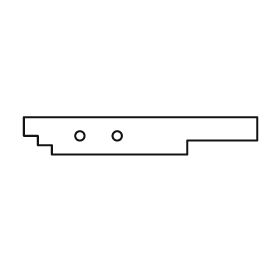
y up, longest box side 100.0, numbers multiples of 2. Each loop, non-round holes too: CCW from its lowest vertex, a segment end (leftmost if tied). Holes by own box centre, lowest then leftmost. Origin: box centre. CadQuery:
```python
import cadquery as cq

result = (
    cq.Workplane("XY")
    .moveTo(-38.0, -8.0)
    .lineTo(20.0, -8.0)
    .lineTo(20.0, -2.0)
    .lineTo(50.0, -2.0)
    .lineTo(50.0, 8.0)
    .lineTo(-50.0, 8.0)
    .lineTo(-50.0, 0.0)
    .lineTo(-44.0, 0.0)
    .lineTo(-44.0, -4.0)
    .lineTo(-38.0, -4.0)
    .close()
    .moveTo(-26.0, 0.0)
    .circle(2.0)
    .moveTo(-10.0, 0.0)
    .circle(2.0)
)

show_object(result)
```